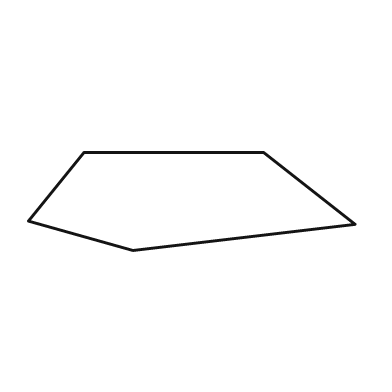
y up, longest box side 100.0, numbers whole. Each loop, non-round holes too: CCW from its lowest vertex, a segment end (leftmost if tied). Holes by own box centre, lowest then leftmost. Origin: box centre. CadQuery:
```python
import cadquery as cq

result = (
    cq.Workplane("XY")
    .moveTo(-18.0, -15.0)
    .lineTo(50.0, -7.0)
    .lineTo(22.0, 15.0)
    .lineTo(-33.0, 15.0)
    .lineTo(-50.0, -6.0)
    .close()
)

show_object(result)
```